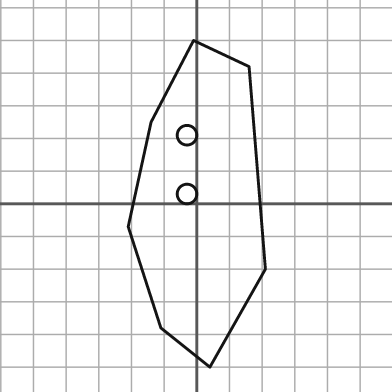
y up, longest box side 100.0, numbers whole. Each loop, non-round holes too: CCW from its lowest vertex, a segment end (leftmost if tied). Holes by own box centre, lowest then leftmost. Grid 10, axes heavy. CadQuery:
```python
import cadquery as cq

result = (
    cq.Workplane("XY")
    .moveTo(4.0, -50.0)
    .lineTo(21.0, -20.0)
    .lineTo(16.0, 42.0)
    .lineTo(-1.0, 50.0)
    .lineTo(-14.0, 25.0)
    .lineTo(-21.0, -7.0)
    .lineTo(-11.0, -38.0)
    .close()
    .moveTo(-3.0, 3.0)
    .circle(3.0)
    .moveTo(-3.0, 21.0)
    .circle(3.0)
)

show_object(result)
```